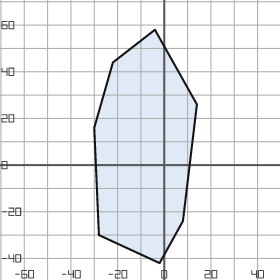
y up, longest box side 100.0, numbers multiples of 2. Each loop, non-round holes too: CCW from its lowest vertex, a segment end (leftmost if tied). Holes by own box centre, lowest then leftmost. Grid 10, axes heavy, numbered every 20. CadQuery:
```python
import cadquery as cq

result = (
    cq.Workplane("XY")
    .moveTo(-2.0, -42.0)
    .lineTo(8.0, -24.0)
    .lineTo(14.0, 26.0)
    .lineTo(-4.0, 58.0)
    .lineTo(-22.0, 44.0)
    .lineTo(-30.0, 16.0)
    .lineTo(-28.0, -30.0)
    .close()
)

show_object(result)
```